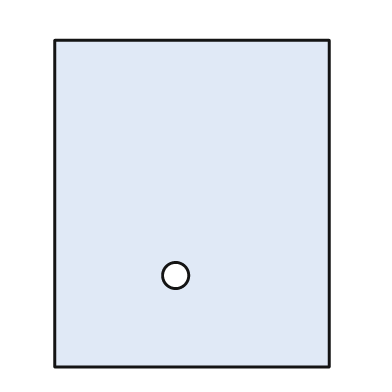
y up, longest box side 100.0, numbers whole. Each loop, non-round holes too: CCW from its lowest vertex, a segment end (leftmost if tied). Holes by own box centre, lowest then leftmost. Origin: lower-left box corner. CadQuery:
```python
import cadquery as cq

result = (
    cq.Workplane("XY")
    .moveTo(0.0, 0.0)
    .lineTo(84.0, 0.0)
    .lineTo(84.0, 100.0)
    .lineTo(0.0, 100.0)
    .close()
    .moveTo(37.0, 28.0)
    .circle(4.0)
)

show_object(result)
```